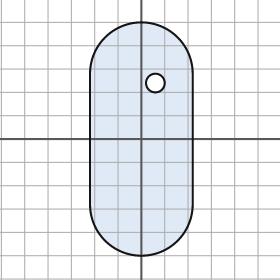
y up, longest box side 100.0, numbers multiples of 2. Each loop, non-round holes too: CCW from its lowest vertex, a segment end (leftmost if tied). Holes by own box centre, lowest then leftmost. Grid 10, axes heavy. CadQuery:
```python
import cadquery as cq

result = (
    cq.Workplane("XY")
    .moveTo(-22.0, -28.0)
    .threePointArc((0.0, -50.0), (22.0, -28.0))
    .lineTo(22.0, 28.0)
    .threePointArc((0.0, 50.0), (-22.0, 28.0))
    .close()
    .moveTo(6.0, 24.0)
    .circle(4.0)
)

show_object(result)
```